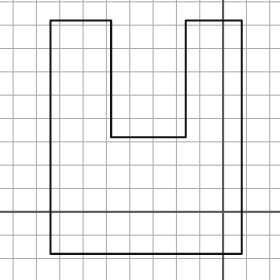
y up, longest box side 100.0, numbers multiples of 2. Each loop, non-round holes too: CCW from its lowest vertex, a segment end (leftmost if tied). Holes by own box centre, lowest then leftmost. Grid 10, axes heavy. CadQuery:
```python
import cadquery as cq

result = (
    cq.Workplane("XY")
    .moveTo(-74.0, -18.0)
    .lineTo(8.0, -18.0)
    .lineTo(8.0, 82.0)
    .lineTo(-16.0, 82.0)
    .lineTo(-16.0, 32.0)
    .lineTo(-48.0, 32.0)
    .lineTo(-48.0, 82.0)
    .lineTo(-74.0, 82.0)
    .close()
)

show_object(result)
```